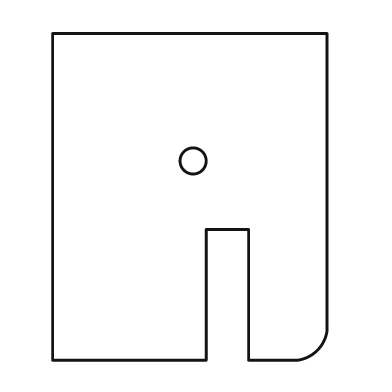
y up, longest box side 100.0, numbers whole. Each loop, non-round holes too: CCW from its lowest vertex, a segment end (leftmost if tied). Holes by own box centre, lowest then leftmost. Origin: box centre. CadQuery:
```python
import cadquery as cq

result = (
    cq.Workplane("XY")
    .moveTo(-42.0, -50.0)
    .lineTo(5.0, -50.0)
    .lineTo(5.0, -10.0)
    .lineTo(18.0, -10.0)
    .lineTo(18.0, -50.0)
    .lineTo(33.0, -50.0)
    .threePointArc((39.0, -47.0), (42.0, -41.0))
    .lineTo(42.0, 50.0)
    .lineTo(-42.0, 50.0)
    .close()
    .moveTo(1.0, 11.0)
    .circle(4.0)
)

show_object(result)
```